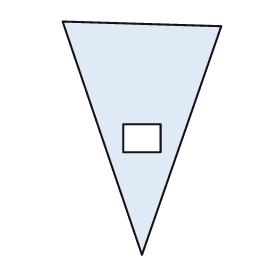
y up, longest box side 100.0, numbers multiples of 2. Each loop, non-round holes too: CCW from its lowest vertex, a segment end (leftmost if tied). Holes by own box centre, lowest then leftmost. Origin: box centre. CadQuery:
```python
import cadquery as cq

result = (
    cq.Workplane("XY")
    .moveTo(0.0, -50.0)
    .lineTo(34.0, 48.0)
    .lineTo(-34.0, 50.0)
    .close()
    .moveTo(-8.0, -6.0)
    .lineTo(8.0, -6.0)
    .lineTo(8.0, 6.0)
    .lineTo(-8.0, 6.0)
    .close()
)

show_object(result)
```